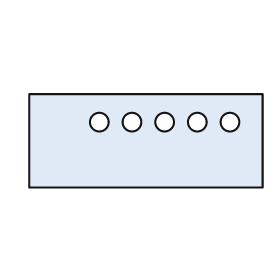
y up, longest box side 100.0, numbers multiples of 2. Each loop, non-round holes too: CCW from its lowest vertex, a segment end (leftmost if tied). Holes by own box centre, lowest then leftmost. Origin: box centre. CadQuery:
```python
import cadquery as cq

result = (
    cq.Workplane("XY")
    .moveTo(-50.0, -20.0)
    .lineTo(50.0, -20.0)
    .lineTo(50.0, 20.0)
    .lineTo(-50.0, 20.0)
    .close()
    .moveTo(-20.0, 8.0)
    .circle(4.0)
    .moveTo(-6.0, 8.0)
    .circle(4.0)
    .moveTo(8.0, 8.0)
    .circle(4.0)
    .moveTo(22.0, 8.0)
    .circle(4.0)
    .moveTo(36.0, 8.0)
    .circle(4.0)
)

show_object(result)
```